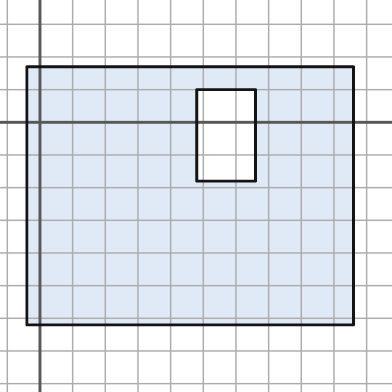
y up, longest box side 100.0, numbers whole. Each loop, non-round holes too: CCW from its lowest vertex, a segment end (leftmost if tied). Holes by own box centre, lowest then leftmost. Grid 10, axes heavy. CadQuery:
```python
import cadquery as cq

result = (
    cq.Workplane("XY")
    .moveTo(-4.0, -62.0)
    .lineTo(96.0, -62.0)
    .lineTo(96.0, 17.0)
    .lineTo(-4.0, 17.0)
    .close()
    .moveTo(48.0, -18.0)
    .lineTo(66.0, -18.0)
    .lineTo(66.0, 10.0)
    .lineTo(48.0, 10.0)
    .close()
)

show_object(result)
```